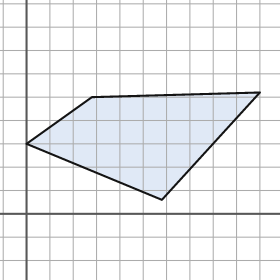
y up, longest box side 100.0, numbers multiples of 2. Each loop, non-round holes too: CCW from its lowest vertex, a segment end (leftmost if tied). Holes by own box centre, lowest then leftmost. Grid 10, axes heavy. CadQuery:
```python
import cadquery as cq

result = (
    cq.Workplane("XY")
    .moveTo(58.0, 6.0)
    .lineTo(100.0, 52.0)
    .lineTo(28.0, 50.0)
    .lineTo(0.0, 30.0)
    .close()
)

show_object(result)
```